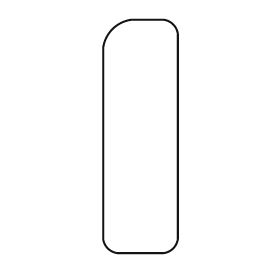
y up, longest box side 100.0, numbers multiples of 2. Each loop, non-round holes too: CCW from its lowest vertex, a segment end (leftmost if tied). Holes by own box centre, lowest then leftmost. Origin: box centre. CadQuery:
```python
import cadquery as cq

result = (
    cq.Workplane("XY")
    .moveTo(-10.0, -50.0)
    .lineTo(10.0, -50.0)
    .threePointArc((14.0, -48.0), (16.0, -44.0))
    .lineTo(16.0, 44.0)
    .threePointArc((14.0, 48.0), (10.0, 50.0))
    .lineTo(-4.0, 50.0)
    .threePointArc((-12.0, 46.0), (-16.0, 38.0))
    .lineTo(-16.0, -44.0)
    .threePointArc((-14.0, -48.0), (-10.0, -50.0))
    .close()
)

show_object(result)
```